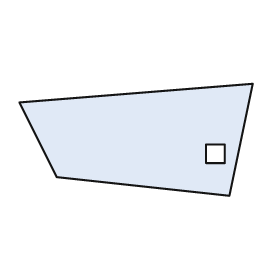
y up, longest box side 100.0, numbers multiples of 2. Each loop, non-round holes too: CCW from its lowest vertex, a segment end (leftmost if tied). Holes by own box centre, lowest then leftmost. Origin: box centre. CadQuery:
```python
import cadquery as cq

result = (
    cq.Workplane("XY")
    .moveTo(40.0, -24.0)
    .lineTo(50.0, 24.0)
    .lineTo(-50.0, 16.0)
    .lineTo(-34.0, -16.0)
    .close()
    .moveTo(30.0, -10.0)
    .lineTo(38.0, -10.0)
    .lineTo(38.0, -2.0)
    .lineTo(30.0, -2.0)
    .close()
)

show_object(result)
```